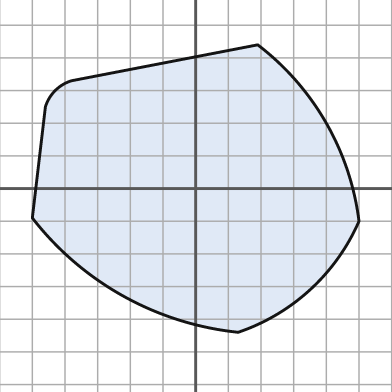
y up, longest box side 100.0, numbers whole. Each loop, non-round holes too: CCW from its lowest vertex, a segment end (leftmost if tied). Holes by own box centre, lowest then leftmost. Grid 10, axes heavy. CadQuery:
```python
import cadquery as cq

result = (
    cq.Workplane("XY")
    .moveTo(13.0, -44.0)
    .threePointArc((35.0, -31.0), (50.0, -10.0))
    .threePointArc((40.0, 20.0), (19.0, 44.0))
    .lineTo(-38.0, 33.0)
    .threePointArc((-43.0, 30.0), (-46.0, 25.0))
    .lineTo(-50.0, -9.0)
    .threePointArc((-22.0, -33.0), (13.0, -44.0))
    .close()
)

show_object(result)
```